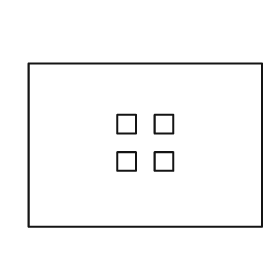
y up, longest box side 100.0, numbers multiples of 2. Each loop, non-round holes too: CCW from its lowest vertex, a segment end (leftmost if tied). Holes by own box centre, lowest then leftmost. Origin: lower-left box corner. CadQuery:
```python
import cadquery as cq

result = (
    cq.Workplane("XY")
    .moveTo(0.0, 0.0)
    .lineTo(100.0, 0.0)
    .lineTo(100.0, 70.0)
    .lineTo(0.0, 70.0)
    .close()
    .moveTo(38.0, 24.0)
    .lineTo(46.0, 24.0)
    .lineTo(46.0, 32.0)
    .lineTo(38.0, 32.0)
    .close()
    .moveTo(54.0, 24.0)
    .lineTo(62.0, 24.0)
    .lineTo(62.0, 32.0)
    .lineTo(54.0, 32.0)
    .close()
    .moveTo(38.0, 40.0)
    .lineTo(46.0, 40.0)
    .lineTo(46.0, 48.0)
    .lineTo(38.0, 48.0)
    .close()
    .moveTo(54.0, 40.0)
    .lineTo(62.0, 40.0)
    .lineTo(62.0, 48.0)
    .lineTo(54.0, 48.0)
    .close()
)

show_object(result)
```